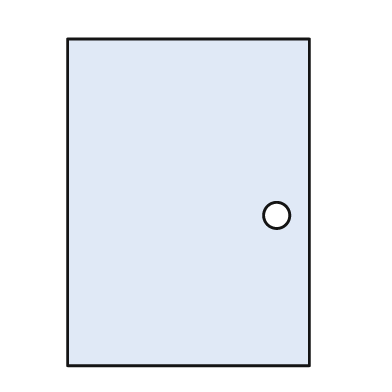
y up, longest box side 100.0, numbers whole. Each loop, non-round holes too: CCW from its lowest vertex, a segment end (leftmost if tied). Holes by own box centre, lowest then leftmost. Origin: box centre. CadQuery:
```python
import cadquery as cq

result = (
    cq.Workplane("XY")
    .moveTo(-37.0, -50.0)
    .lineTo(37.0, -50.0)
    .lineTo(37.0, 50.0)
    .lineTo(-37.0, 50.0)
    .close()
    .moveTo(27.0, -4.0)
    .circle(4.0)
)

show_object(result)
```